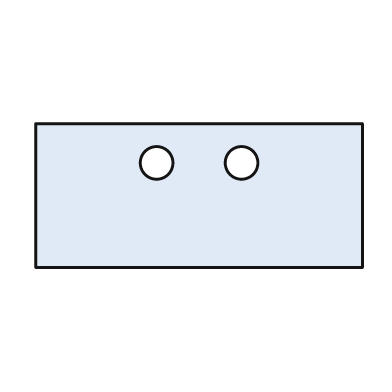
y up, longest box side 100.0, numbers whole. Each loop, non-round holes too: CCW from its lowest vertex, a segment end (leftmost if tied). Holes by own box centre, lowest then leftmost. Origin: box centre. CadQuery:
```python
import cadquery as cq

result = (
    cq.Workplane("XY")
    .moveTo(-50.0, -22.0)
    .lineTo(50.0, -22.0)
    .lineTo(50.0, 22.0)
    .lineTo(-50.0, 22.0)
    .close()
    .moveTo(-13.0, 10.0)
    .circle(5.0)
    .moveTo(13.0, 10.0)
    .circle(5.0)
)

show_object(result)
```